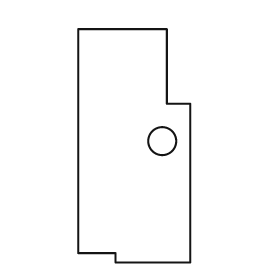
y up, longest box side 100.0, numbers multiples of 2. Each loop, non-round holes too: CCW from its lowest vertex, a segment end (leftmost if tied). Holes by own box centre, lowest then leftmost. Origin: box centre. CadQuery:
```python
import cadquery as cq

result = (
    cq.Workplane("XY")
    .moveTo(-8.0, -50.0)
    .lineTo(24.0, -50.0)
    .lineTo(24.0, 18.0)
    .lineTo(14.0, 18.0)
    .lineTo(14.0, 50.0)
    .lineTo(-24.0, 50.0)
    .lineTo(-24.0, -46.0)
    .lineTo(-8.0, -46.0)
    .close()
    .moveTo(12.0, 2.0)
    .circle(6.0)
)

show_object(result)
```